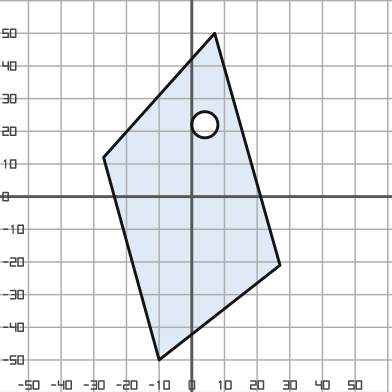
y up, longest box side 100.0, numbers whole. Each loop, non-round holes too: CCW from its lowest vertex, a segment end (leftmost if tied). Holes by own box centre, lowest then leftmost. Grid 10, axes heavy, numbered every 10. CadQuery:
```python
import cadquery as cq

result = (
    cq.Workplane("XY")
    .moveTo(-10.0, -50.0)
    .lineTo(27.0, -21.0)
    .lineTo(7.0, 50.0)
    .lineTo(-27.0, 12.0)
    .close()
    .moveTo(4.0, 22.0)
    .circle(4.0)
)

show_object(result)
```